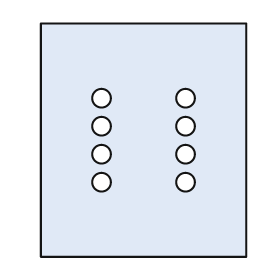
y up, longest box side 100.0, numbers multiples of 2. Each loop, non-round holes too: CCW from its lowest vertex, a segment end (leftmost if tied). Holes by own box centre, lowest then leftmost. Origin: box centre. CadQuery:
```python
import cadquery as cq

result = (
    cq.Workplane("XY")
    .moveTo(-44.0, -50.0)
    .lineTo(44.0, -50.0)
    .lineTo(44.0, 50.0)
    .lineTo(-44.0, 50.0)
    .close()
    .moveTo(-18.0, -18.0)
    .circle(4.0)
    .moveTo(18.0, -18.0)
    .circle(4.0)
    .moveTo(-18.0, -6.0)
    .circle(4.0)
    .moveTo(18.0, -6.0)
    .circle(4.0)
    .moveTo(-18.0, 6.0)
    .circle(4.0)
    .moveTo(18.0, 6.0)
    .circle(4.0)
    .moveTo(-18.0, 18.0)
    .circle(4.0)
    .moveTo(18.0, 18.0)
    .circle(4.0)
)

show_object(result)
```